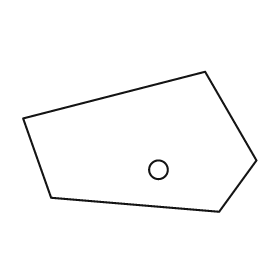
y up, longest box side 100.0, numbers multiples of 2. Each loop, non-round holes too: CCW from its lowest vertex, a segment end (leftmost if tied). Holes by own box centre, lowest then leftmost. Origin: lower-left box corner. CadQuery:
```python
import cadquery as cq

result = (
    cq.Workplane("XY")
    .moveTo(84.0, 0.0)
    .lineTo(100.0, 22.0)
    .lineTo(78.0, 60.0)
    .lineTo(0.0, 40.0)
    .lineTo(12.0, 6.0)
    .close()
    .moveTo(58.0, 18.0)
    .circle(4.0)
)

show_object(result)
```